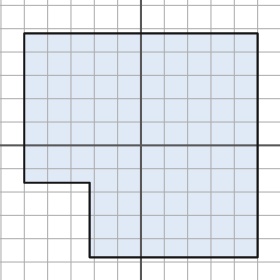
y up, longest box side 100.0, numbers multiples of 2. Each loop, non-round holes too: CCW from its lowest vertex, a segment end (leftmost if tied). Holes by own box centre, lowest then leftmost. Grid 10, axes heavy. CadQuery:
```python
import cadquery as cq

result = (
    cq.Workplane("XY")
    .moveTo(-22.0, -48.0)
    .lineTo(50.0, -48.0)
    .lineTo(50.0, 48.0)
    .lineTo(-50.0, 48.0)
    .lineTo(-50.0, -16.0)
    .lineTo(-22.0, -16.0)
    .close()
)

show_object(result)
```